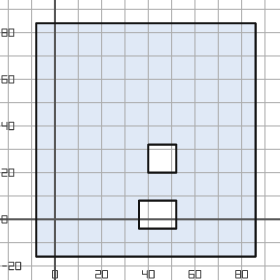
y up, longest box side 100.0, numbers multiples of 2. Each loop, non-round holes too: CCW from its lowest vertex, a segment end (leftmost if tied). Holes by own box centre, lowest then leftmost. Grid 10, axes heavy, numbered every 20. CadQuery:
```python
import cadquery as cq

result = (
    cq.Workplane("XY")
    .moveTo(-8.0, -16.0)
    .lineTo(86.0, -16.0)
    .lineTo(86.0, 84.0)
    .lineTo(-8.0, 84.0)
    .close()
    .moveTo(36.0, -4.0)
    .lineTo(52.0, -4.0)
    .lineTo(52.0, 8.0)
    .lineTo(36.0, 8.0)
    .close()
    .moveTo(40.0, 20.0)
    .lineTo(52.0, 20.0)
    .lineTo(52.0, 32.0)
    .lineTo(40.0, 32.0)
    .close()
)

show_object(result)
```